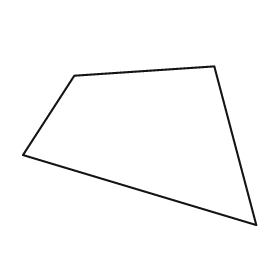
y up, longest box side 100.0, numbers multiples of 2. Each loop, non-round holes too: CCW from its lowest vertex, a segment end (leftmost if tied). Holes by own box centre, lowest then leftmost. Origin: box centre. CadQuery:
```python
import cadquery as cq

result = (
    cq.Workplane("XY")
    .moveTo(50.0, -34.0)
    .lineTo(32.0, 34.0)
    .lineTo(-28.0, 30.0)
    .lineTo(-50.0, -4.0)
    .close()
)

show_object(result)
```